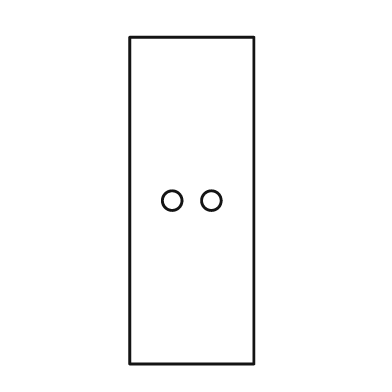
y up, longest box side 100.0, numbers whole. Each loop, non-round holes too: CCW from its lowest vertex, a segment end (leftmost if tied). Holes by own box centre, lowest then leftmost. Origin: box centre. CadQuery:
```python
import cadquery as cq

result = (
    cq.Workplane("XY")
    .moveTo(-19.0, -50.0)
    .lineTo(19.0, -50.0)
    .lineTo(19.0, 50.0)
    .lineTo(-19.0, 50.0)
    .close()
    .moveTo(-6.0, 0.0)
    .circle(3.0)
    .moveTo(6.0, 0.0)
    .circle(3.0)
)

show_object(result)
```